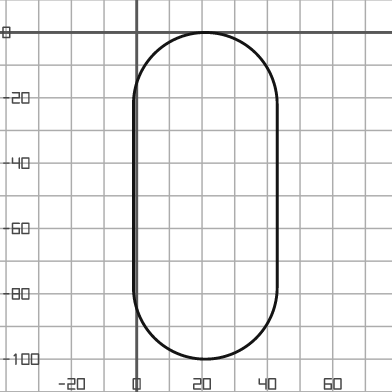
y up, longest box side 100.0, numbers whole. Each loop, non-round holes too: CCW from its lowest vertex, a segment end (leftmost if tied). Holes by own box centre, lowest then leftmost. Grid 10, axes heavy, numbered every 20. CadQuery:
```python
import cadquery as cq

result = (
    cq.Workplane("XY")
    .moveTo(-1.0, -78.0)
    .threePointArc((21.0, -100.0), (43.0, -78.0))
    .lineTo(43.0, -22.0)
    .threePointArc((21.0, 0.0), (-1.0, -22.0))
    .close()
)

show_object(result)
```